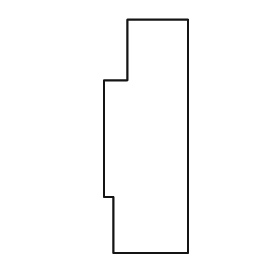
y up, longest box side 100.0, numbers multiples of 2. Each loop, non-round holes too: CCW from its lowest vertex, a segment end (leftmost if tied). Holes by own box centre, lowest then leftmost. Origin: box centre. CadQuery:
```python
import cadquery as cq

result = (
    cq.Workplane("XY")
    .moveTo(-14.0, -50.0)
    .lineTo(18.0, -50.0)
    .lineTo(18.0, 50.0)
    .lineTo(-8.0, 50.0)
    .lineTo(-8.0, 24.0)
    .lineTo(-18.0, 24.0)
    .lineTo(-18.0, -26.0)
    .lineTo(-14.0, -26.0)
    .close()
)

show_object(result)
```